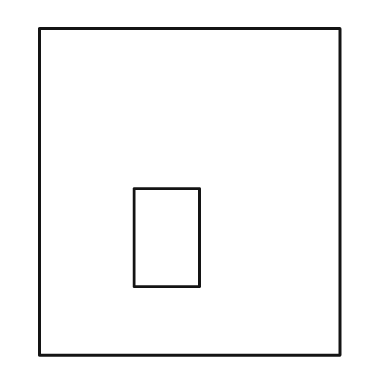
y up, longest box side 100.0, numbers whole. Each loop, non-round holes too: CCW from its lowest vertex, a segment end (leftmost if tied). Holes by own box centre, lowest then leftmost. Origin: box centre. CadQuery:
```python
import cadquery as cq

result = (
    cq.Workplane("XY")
    .moveTo(-46.0, -50.0)
    .lineTo(46.0, -50.0)
    .lineTo(46.0, 50.0)
    .lineTo(-46.0, 50.0)
    .close()
    .moveTo(-17.0, -29.0)
    .lineTo(3.0, -29.0)
    .lineTo(3.0, 1.0)
    .lineTo(-17.0, 1.0)
    .close()
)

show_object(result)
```